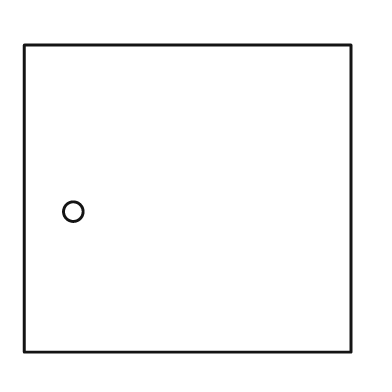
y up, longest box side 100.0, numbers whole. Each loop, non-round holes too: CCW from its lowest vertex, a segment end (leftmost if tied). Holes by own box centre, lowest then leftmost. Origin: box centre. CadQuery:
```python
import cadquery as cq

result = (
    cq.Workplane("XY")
    .moveTo(-50.0, -47.0)
    .lineTo(50.0, -47.0)
    .lineTo(50.0, 47.0)
    .lineTo(-50.0, 47.0)
    .close()
    .moveTo(-35.0, -4.0)
    .circle(3.0)
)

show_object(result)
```